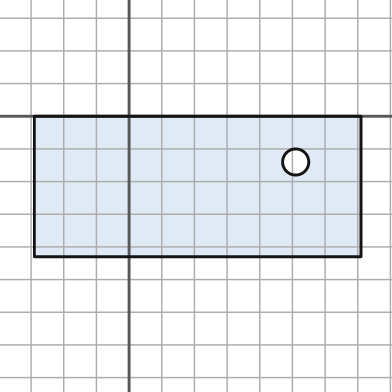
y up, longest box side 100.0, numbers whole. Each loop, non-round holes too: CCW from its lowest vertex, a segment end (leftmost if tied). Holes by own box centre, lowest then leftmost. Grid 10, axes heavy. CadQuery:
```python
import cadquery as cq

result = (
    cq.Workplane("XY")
    .moveTo(-29.0, -43.0)
    .lineTo(71.0, -43.0)
    .lineTo(71.0, 0.0)
    .lineTo(-29.0, 0.0)
    .close()
    .moveTo(51.0, -14.0)
    .circle(4.0)
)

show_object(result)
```